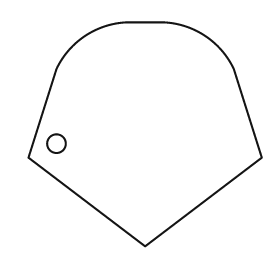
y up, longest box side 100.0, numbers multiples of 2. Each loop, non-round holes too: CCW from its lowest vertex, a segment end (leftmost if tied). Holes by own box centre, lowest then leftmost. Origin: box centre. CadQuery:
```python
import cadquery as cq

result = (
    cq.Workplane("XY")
    .moveTo(0.0, -48.0)
    .lineTo(50.0, -10.0)
    .lineTo(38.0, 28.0)
    .threePointArc((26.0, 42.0), (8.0, 48.0))
    .lineTo(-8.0, 48.0)
    .threePointArc((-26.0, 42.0), (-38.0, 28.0))
    .lineTo(-50.0, -10.0)
    .close()
    .moveTo(-38.0, -4.0)
    .circle(4.0)
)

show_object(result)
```